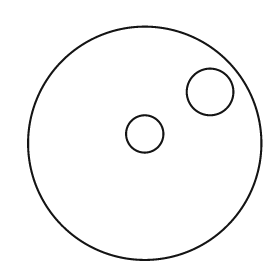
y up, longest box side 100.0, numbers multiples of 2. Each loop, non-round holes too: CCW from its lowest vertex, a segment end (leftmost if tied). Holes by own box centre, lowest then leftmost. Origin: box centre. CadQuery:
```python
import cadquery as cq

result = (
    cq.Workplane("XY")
    .moveTo(0.0, 0.0)
    .circle(50.0)
    .moveTo(0.0, 4.0)
    .circle(8.0)
    .moveTo(28.0, 22.0)
    .circle(10.0)
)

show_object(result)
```